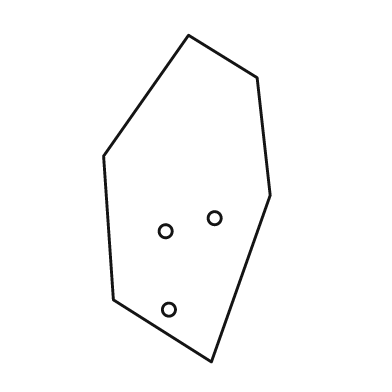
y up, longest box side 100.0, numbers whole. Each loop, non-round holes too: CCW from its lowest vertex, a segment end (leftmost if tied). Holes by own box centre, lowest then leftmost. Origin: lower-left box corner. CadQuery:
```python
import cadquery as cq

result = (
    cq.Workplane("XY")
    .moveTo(33.0, 0.0)
    .lineTo(51.0, 51.0)
    .lineTo(47.0, 87.0)
    .lineTo(26.0, 100.0)
    .lineTo(0.0, 63.0)
    .lineTo(3.0, 19.0)
    .close()
    .moveTo(20.0, 16.0)
    .circle(2.0)
    .moveTo(19.0, 40.0)
    .circle(2.0)
    .moveTo(34.0, 44.0)
    .circle(2.0)
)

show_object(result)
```